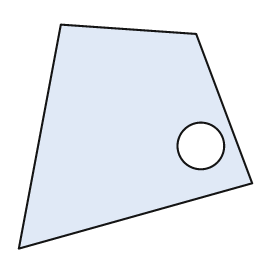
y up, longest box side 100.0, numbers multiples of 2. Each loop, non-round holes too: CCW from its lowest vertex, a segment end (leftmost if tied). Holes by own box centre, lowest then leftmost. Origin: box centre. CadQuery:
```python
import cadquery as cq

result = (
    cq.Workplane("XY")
    .moveTo(-50.0, -48.0)
    .lineTo(50.0, -20.0)
    .lineTo(26.0, 44.0)
    .lineTo(-32.0, 48.0)
    .close()
    .moveTo(28.0, -4.0)
    .circle(10.0)
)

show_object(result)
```